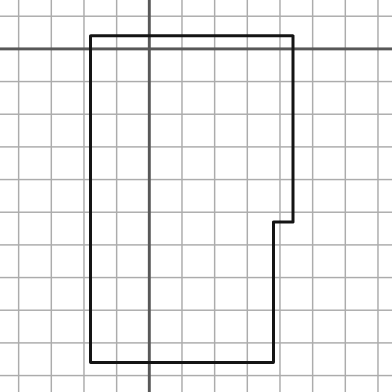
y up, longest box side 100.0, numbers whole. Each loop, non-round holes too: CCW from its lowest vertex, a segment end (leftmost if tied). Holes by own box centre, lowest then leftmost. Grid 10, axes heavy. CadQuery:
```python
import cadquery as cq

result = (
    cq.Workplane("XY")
    .moveTo(-18.0, -96.0)
    .lineTo(38.0, -96.0)
    .lineTo(38.0, -53.0)
    .lineTo(44.0, -53.0)
    .lineTo(44.0, 4.0)
    .lineTo(-18.0, 4.0)
    .close()
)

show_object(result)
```